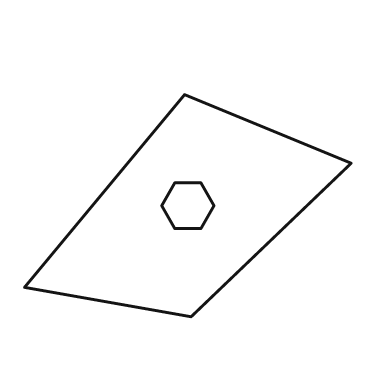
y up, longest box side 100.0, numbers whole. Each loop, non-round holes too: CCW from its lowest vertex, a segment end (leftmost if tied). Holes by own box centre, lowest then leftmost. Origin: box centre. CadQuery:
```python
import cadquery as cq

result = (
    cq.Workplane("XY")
    .moveTo(1.0, -34.0)
    .lineTo(50.0, 13.0)
    .lineTo(-1.0, 34.0)
    .lineTo(-50.0, -25.0)
    .close()
    .moveTo(-4.0, -7.0)
    .lineTo(4.0, -7.0)
    .lineTo(8.0, 0.0)
    .lineTo(4.0, 7.0)
    .lineTo(-4.0, 7.0)
    .lineTo(-8.0, 0.0)
    .close()
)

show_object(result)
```